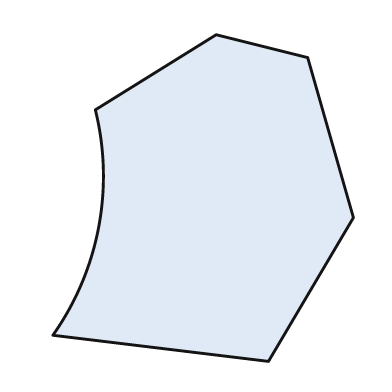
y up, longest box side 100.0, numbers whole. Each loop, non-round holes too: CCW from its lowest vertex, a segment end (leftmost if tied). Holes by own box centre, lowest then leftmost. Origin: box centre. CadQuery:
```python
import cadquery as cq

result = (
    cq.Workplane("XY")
    .moveTo(20.0, -50.0)
    .lineTo(46.0, -6.0)
    .lineTo(32.0, 43.0)
    .lineTo(4.0, 50.0)
    .lineTo(-33.0, 27.0)
    .threePointArc((-32.0, -9.0), (-46.0, -42.0))
    .close()
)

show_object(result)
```